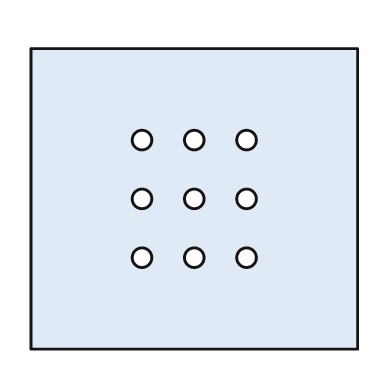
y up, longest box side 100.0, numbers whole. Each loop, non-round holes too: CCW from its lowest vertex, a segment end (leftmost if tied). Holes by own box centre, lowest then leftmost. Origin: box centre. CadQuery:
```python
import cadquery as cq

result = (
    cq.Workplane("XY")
    .moveTo(-50.0, -46.0)
    .lineTo(50.0, -46.0)
    .lineTo(50.0, 46.0)
    .lineTo(-50.0, 46.0)
    .close()
    .moveTo(-16.0, -18.0)
    .circle(3.0)
    .moveTo(0.0, -18.0)
    .circle(3.0)
    .moveTo(16.0, -18.0)
    .circle(3.0)
    .moveTo(-16.0, 0.0)
    .circle(3.0)
    .moveTo(0.0, 0.0)
    .circle(3.0)
    .moveTo(16.0, 0.0)
    .circle(3.0)
    .moveTo(-16.0, 18.0)
    .circle(3.0)
    .moveTo(0.0, 18.0)
    .circle(3.0)
    .moveTo(16.0, 18.0)
    .circle(3.0)
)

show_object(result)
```